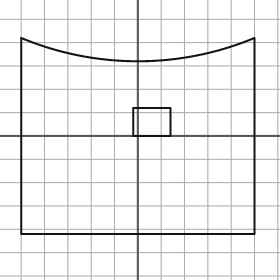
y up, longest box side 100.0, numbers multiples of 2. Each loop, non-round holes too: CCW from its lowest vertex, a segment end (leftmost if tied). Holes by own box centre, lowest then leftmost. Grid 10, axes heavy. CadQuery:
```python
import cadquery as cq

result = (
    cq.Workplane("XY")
    .moveTo(-50.0, -42.0)
    .lineTo(50.0, -42.0)
    .lineTo(50.0, 42.0)
    .threePointArc((0.0, 32.0), (-50.0, 42.0))
    .close()
    .moveTo(-2.0, 0.0)
    .lineTo(14.0, 0.0)
    .lineTo(14.0, 12.0)
    .lineTo(-2.0, 12.0)
    .close()
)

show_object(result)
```